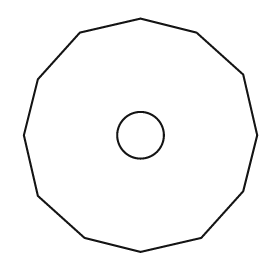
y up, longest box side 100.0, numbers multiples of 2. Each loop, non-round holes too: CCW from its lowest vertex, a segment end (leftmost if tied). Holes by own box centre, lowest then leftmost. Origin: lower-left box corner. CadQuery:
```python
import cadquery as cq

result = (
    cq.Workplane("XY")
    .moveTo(50.0, 0.0)
    .lineTo(76.0, 6.0)
    .lineTo(94.0, 26.0)
    .lineTo(100.0, 50.0)
    .lineTo(94.0, 76.0)
    .lineTo(74.0, 94.0)
    .lineTo(50.0, 100.0)
    .lineTo(24.0, 94.0)
    .lineTo(6.0, 74.0)
    .lineTo(0.0, 50.0)
    .lineTo(6.0, 24.0)
    .lineTo(26.0, 6.0)
    .close()
    .moveTo(50.0, 50.0)
    .circle(10.0)
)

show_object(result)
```